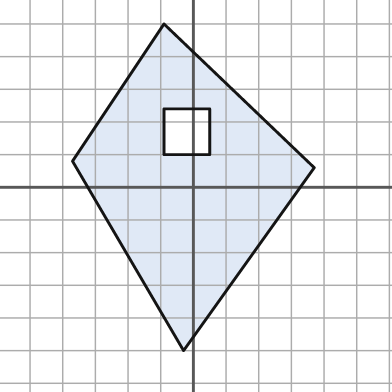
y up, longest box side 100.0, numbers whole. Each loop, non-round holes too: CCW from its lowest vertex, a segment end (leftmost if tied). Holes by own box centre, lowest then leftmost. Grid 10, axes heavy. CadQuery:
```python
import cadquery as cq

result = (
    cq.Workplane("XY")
    .moveTo(-3.0, -50.0)
    .lineTo(37.0, 6.0)
    .lineTo(-9.0, 50.0)
    .lineTo(-37.0, 8.0)
    .close()
    .moveTo(-9.0, 10.0)
    .lineTo(5.0, 10.0)
    .lineTo(5.0, 24.0)
    .lineTo(-9.0, 24.0)
    .close()
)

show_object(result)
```